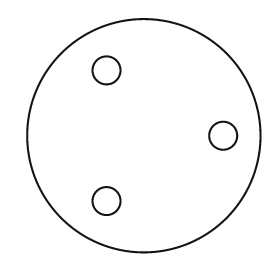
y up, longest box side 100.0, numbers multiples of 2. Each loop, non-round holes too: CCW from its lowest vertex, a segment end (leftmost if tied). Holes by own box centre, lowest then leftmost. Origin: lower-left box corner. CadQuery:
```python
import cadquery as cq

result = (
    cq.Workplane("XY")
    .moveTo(50.0, 50.0)
    .circle(50.0)
    .moveTo(34.0, 22.0)
    .circle(6.0)
    .moveTo(84.0, 50.0)
    .circle(6.0)
    .moveTo(34.0, 78.0)
    .circle(6.0)
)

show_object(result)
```